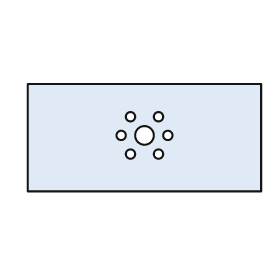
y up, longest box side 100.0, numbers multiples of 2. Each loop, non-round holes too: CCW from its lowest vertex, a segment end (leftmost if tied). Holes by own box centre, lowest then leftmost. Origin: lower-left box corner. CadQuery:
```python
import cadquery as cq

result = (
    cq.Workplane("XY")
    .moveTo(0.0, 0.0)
    .lineTo(100.0, 0.0)
    .lineTo(100.0, 46.0)
    .lineTo(0.0, 46.0)
    .close()
    .moveTo(44.0, 16.0)
    .circle(2.0)
    .moveTo(56.0, 16.0)
    .circle(2.0)
    .moveTo(40.0, 24.0)
    .circle(2.0)
    .moveTo(50.0, 24.0)
    .circle(4.0)
    .moveTo(60.0, 24.0)
    .circle(2.0)
    .moveTo(44.0, 32.0)
    .circle(2.0)
    .moveTo(56.0, 32.0)
    .circle(2.0)
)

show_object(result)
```